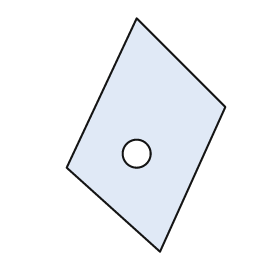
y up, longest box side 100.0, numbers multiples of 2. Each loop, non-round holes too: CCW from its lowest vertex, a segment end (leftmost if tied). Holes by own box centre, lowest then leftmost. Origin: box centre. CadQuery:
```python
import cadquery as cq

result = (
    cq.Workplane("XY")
    .moveTo(6.0, -50.0)
    .lineTo(34.0, 12.0)
    .lineTo(-4.0, 50.0)
    .lineTo(-34.0, -14.0)
    .close()
    .moveTo(-4.0, -8.0)
    .circle(6.0)
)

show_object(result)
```